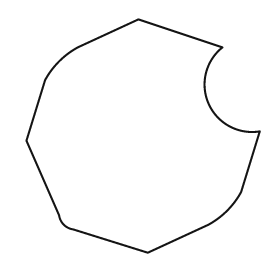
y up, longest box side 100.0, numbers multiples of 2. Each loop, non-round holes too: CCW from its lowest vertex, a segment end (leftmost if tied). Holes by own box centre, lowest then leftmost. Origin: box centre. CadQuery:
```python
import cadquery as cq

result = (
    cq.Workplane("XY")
    .moveTo(2.0, -50.0)
    .lineTo(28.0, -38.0)
    .threePointArc((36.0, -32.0), (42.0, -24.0))
    .lineTo(50.0, 2.0)
    .threePointArc((28.0, 14.0), (34.0, 38.0))
    .lineTo(-2.0, 50.0)
    .lineTo(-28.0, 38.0)
    .threePointArc((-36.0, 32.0), (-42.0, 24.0))
    .lineTo(-50.0, -2.0)
    .lineTo(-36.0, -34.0)
    .threePointArc((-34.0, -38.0), (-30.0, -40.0))
    .close()
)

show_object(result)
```